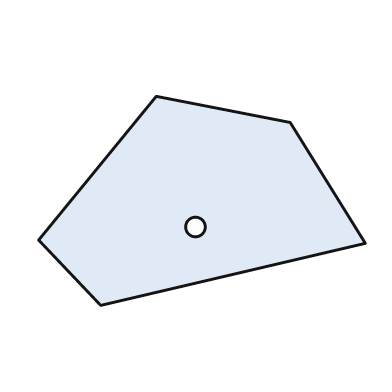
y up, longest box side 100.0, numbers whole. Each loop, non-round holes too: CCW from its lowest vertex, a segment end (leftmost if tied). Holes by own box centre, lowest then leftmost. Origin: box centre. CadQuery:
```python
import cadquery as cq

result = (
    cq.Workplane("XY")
    .moveTo(-31.0, -32.0)
    .lineTo(50.0, -13.0)
    .lineTo(27.0, 24.0)
    .lineTo(-14.0, 32.0)
    .lineTo(-50.0, -12.0)
    .close()
    .moveTo(-2.0, -8.0)
    .circle(3.0)
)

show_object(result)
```